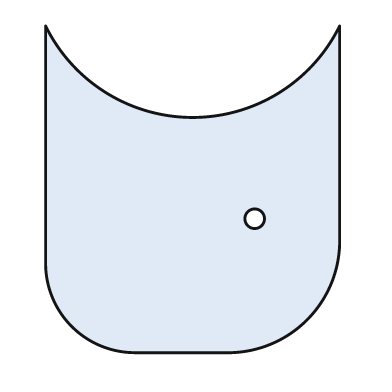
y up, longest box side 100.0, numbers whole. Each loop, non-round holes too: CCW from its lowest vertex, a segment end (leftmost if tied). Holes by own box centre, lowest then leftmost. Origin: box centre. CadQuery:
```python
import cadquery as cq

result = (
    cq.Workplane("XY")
    .moveTo(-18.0, -50.0)
    .lineTo(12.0, -50.0)
    .threePointArc((35.0, -40.0), (45.0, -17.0))
    .lineTo(45.0, 50.0)
    .threePointArc((0.0, 22.0), (-45.0, 50.0))
    .lineTo(-45.0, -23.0)
    .threePointArc((-37.0, -42.0), (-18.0, -50.0))
    .close()
    .moveTo(19.0, -9.0)
    .circle(3.0)
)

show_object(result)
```